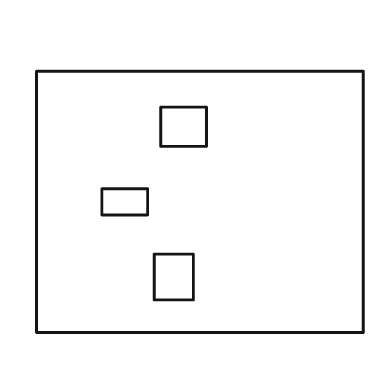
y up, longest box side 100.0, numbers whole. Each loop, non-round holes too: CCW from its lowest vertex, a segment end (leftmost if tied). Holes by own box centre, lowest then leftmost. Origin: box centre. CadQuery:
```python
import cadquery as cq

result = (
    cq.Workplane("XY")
    .moveTo(-50.0, -40.0)
    .lineTo(50.0, -40.0)
    .lineTo(50.0, 40.0)
    .lineTo(-50.0, 40.0)
    .close()
    .moveTo(-14.0, -30.0)
    .lineTo(-2.0, -30.0)
    .lineTo(-2.0, -16.0)
    .lineTo(-14.0, -16.0)
    .close()
    .moveTo(-30.0, -4.0)
    .lineTo(-16.0, -4.0)
    .lineTo(-16.0, 4.0)
    .lineTo(-30.0, 4.0)
    .close()
    .moveTo(-12.0, 17.0)
    .lineTo(2.0, 17.0)
    .lineTo(2.0, 29.0)
    .lineTo(-12.0, 29.0)
    .close()
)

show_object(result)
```